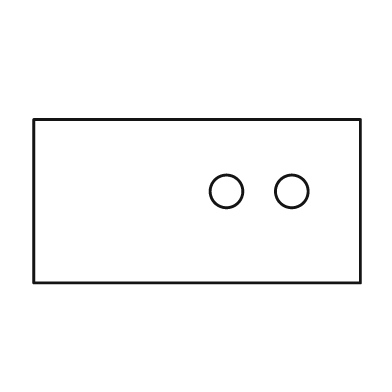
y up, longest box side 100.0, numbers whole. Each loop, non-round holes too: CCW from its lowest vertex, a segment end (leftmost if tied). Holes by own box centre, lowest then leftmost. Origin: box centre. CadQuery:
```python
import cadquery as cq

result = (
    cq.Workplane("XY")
    .moveTo(-50.0, -25.0)
    .lineTo(50.0, -25.0)
    .lineTo(50.0, 25.0)
    .lineTo(-50.0, 25.0)
    .close()
    .moveTo(9.0, 3.0)
    .circle(5.0)
    .moveTo(29.0, 3.0)
    .circle(5.0)
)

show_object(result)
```